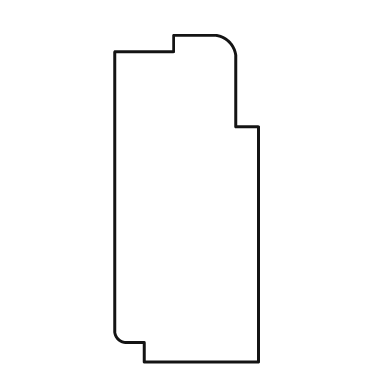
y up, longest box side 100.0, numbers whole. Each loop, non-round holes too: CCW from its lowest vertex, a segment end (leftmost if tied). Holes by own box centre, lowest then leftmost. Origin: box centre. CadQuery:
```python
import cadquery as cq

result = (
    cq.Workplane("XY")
    .moveTo(-13.0, -50.0)
    .lineTo(22.0, -50.0)
    .lineTo(22.0, 22.0)
    .lineTo(15.0, 22.0)
    .lineTo(15.0, 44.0)
    .threePointArc((13.0, 48.0), (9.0, 50.0))
    .lineTo(-4.0, 50.0)
    .lineTo(-4.0, 45.0)
    .lineTo(-22.0, 45.0)
    .lineTo(-22.0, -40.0)
    .threePointArc((-21.0, -43.0), (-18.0, -44.0))
    .lineTo(-13.0, -44.0)
    .close()
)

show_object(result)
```